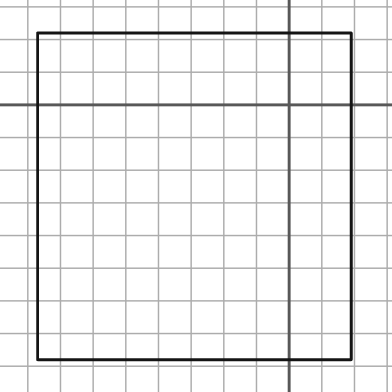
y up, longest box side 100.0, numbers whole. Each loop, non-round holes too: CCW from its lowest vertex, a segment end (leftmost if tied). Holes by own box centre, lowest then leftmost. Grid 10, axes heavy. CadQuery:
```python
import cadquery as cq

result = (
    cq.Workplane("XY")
    .moveTo(-77.0, -78.0)
    .lineTo(19.0, -78.0)
    .lineTo(19.0, 22.0)
    .lineTo(-77.0, 22.0)
    .close()
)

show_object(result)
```